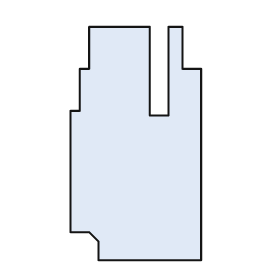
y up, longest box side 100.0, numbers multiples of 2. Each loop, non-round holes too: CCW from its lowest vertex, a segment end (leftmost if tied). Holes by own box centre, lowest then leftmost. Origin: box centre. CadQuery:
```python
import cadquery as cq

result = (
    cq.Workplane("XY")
    .moveTo(-16.0, -50.0)
    .lineTo(28.0, -50.0)
    .lineTo(28.0, 32.0)
    .lineTo(20.0, 32.0)
    .lineTo(20.0, 50.0)
    .lineTo(14.0, 50.0)
    .lineTo(14.0, 12.0)
    .lineTo(6.0, 12.0)
    .lineTo(6.0, 50.0)
    .lineTo(-20.0, 50.0)
    .lineTo(-20.0, 32.0)
    .lineTo(-24.0, 32.0)
    .lineTo(-24.0, 14.0)
    .lineTo(-28.0, 14.0)
    .lineTo(-28.0, -38.0)
    .lineTo(-20.0, -38.0)
    .lineTo(-16.0, -42.0)
    .close()
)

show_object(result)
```